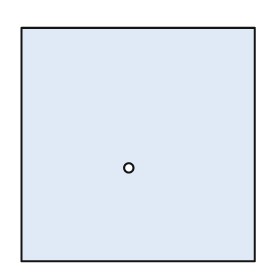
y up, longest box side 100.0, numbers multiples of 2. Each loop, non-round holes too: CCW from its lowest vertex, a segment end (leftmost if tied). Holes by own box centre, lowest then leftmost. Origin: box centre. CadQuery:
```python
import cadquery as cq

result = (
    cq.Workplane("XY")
    .moveTo(-50.0, -50.0)
    .lineTo(50.0, -50.0)
    .lineTo(50.0, 50.0)
    .lineTo(-50.0, 50.0)
    .close()
    .moveTo(-4.0, -10.0)
    .circle(2.0)
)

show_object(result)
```